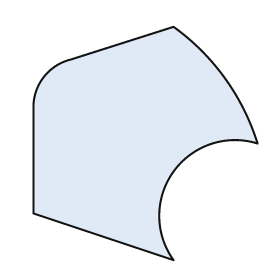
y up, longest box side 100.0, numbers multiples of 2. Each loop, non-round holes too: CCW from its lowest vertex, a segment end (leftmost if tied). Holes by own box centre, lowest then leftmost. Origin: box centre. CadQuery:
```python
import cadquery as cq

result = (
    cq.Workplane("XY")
    .moveTo(12.0, -50.0)
    .threePointArc((12.0, -12.0), (48.0, 0.0))
    .threePointArc((34.0, 28.0), (12.0, 50.0))
    .lineTo(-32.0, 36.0)
    .threePointArc((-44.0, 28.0), (-48.0, 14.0))
    .lineTo(-48.0, -30.0)
    .close()
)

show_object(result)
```